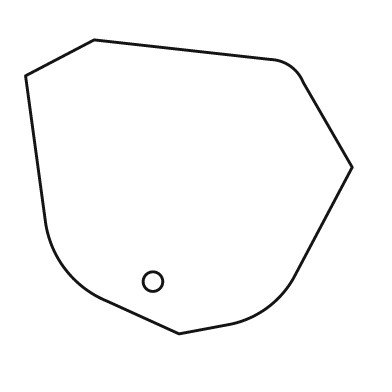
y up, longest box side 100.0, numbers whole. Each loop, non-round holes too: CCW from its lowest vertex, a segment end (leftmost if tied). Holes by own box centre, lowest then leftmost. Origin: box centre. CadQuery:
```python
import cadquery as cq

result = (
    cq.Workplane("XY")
    .moveTo(-3.0, -45.0)
    .lineTo(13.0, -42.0)
    .threePointArc((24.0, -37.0), (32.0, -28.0))
    .lineTo(50.0, 6.0)
    .lineTo(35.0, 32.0)
    .threePointArc((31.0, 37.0), (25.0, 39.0))
    .lineTo(-29.0, 45.0)
    .lineTo(-50.0, 34.0)
    .lineTo(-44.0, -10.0)
    .threePointArc((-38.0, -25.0), (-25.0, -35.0))
    .close()
    .moveTo(-11.0, -29.0)
    .circle(3.0)
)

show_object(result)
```